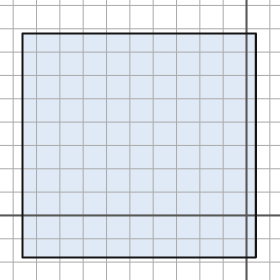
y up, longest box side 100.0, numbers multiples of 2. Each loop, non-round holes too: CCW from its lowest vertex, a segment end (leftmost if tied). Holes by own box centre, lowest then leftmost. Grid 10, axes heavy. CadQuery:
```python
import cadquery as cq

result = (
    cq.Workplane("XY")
    .moveTo(-96.0, -18.0)
    .lineTo(4.0, -18.0)
    .lineTo(4.0, 78.0)
    .lineTo(-96.0, 78.0)
    .close()
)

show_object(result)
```